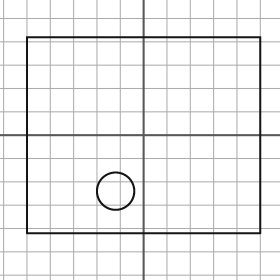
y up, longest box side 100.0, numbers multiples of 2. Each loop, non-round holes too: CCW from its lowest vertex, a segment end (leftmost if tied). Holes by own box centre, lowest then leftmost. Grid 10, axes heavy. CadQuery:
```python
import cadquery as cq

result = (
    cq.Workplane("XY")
    .moveTo(-50.0, -42.0)
    .lineTo(50.0, -42.0)
    .lineTo(50.0, 42.0)
    .lineTo(-50.0, 42.0)
    .close()
    .moveTo(-12.0, -24.0)
    .circle(8.0)
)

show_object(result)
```